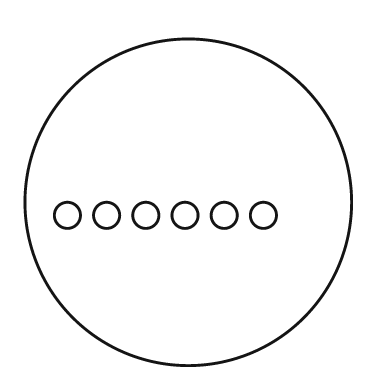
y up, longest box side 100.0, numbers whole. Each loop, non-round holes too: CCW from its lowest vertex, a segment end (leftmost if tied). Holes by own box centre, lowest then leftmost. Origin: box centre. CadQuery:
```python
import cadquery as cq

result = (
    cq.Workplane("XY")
    .moveTo(0.0, 0.0)
    .circle(50.0)
    .moveTo(-37.0, -4.0)
    .circle(4.0)
    .moveTo(-25.0, -4.0)
    .circle(4.0)
    .moveTo(-13.0, -4.0)
    .circle(4.0)
    .moveTo(-1.0, -4.0)
    .circle(4.0)
    .moveTo(11.0, -4.0)
    .circle(4.0)
    .moveTo(23.0, -4.0)
    .circle(4.0)
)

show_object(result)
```